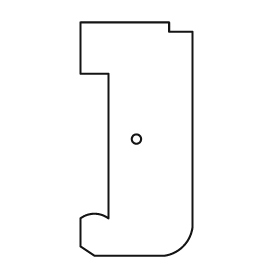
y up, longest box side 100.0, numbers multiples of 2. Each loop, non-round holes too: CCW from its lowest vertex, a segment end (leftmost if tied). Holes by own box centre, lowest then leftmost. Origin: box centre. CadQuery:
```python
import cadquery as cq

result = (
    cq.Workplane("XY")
    .moveTo(-18.0, -50.0)
    .lineTo(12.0, -50.0)
    .threePointArc((20.0, -46.0), (24.0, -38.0))
    .lineTo(24.0, 46.0)
    .lineTo(14.0, 46.0)
    .lineTo(14.0, 50.0)
    .lineTo(-24.0, 50.0)
    .lineTo(-24.0, 28.0)
    .lineTo(-12.0, 28.0)
    .lineTo(-12.0, -34.0)
    .threePointArc((-18.0, -32.0), (-24.0, -34.0))
    .lineTo(-24.0, -46.0)
    .close()
    .moveTo(0.0, 0.0)
    .circle(2.0)
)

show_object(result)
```